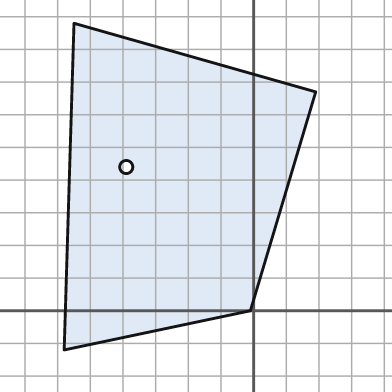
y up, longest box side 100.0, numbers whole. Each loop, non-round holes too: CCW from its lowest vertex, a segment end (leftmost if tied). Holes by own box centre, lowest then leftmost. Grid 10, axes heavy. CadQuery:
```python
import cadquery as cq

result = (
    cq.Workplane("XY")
    .moveTo(-58.0, -12.0)
    .lineTo(-1.0, 0.0)
    .lineTo(19.0, 67.0)
    .lineTo(-55.0, 88.0)
    .close()
    .moveTo(-39.0, 44.0)
    .circle(2.0)
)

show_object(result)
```